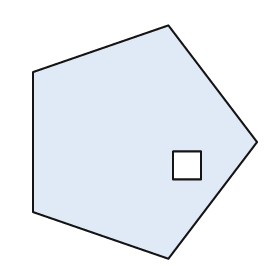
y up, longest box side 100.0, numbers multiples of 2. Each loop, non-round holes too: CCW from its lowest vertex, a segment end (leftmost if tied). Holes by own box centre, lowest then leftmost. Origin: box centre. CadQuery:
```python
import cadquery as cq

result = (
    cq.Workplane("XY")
    .moveTo(10.0, -50.0)
    .lineTo(48.0, 0.0)
    .lineTo(10.0, 50.0)
    .lineTo(-48.0, 30.0)
    .lineTo(-48.0, -30.0)
    .close()
    .moveTo(12.0, -16.0)
    .lineTo(24.0, -16.0)
    .lineTo(24.0, -4.0)
    .lineTo(12.0, -4.0)
    .close()
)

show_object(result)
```